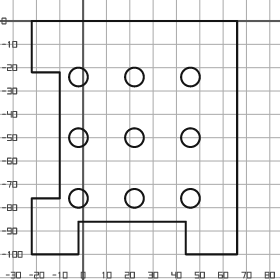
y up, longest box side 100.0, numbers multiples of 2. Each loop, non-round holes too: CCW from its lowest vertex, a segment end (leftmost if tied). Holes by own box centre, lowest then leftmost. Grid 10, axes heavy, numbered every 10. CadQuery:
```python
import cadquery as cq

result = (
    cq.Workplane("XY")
    .moveTo(-22.0, -100.0)
    .lineTo(-2.0, -100.0)
    .lineTo(-2.0, -86.0)
    .lineTo(44.0, -86.0)
    .lineTo(44.0, -100.0)
    .lineTo(66.0, -100.0)
    .lineTo(66.0, 0.0)
    .lineTo(-22.0, 0.0)
    .lineTo(-22.0, -22.0)
    .lineTo(-10.0, -22.0)
    .lineTo(-10.0, -76.0)
    .lineTo(-22.0, -76.0)
    .close()
    .moveTo(-2.0, -76.0)
    .circle(4.0)
    .moveTo(22.0, -76.0)
    .circle(4.0)
    .moveTo(46.0, -76.0)
    .circle(4.0)
    .moveTo(-2.0, -50.0)
    .circle(4.0)
    .moveTo(22.0, -50.0)
    .circle(4.0)
    .moveTo(46.0, -50.0)
    .circle(4.0)
    .moveTo(-2.0, -24.0)
    .circle(4.0)
    .moveTo(22.0, -24.0)
    .circle(4.0)
    .moveTo(46.0, -24.0)
    .circle(4.0)
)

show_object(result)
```